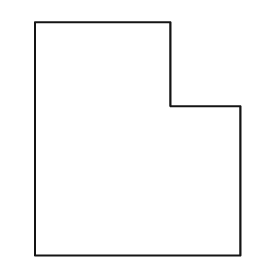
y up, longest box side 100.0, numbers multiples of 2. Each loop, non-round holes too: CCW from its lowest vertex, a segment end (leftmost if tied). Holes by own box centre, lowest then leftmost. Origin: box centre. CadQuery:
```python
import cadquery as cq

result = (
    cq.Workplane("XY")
    .moveTo(-44.0, -50.0)
    .lineTo(44.0, -50.0)
    .lineTo(44.0, 14.0)
    .lineTo(14.0, 14.0)
    .lineTo(14.0, 50.0)
    .lineTo(-44.0, 50.0)
    .close()
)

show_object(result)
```